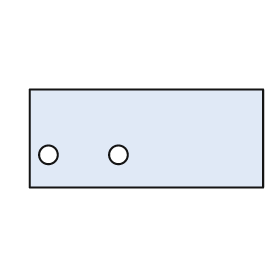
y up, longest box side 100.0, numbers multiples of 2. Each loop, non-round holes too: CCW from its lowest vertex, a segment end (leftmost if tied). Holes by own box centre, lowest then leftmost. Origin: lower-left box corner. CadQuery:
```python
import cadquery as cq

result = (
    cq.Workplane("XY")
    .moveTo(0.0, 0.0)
    .lineTo(100.0, 0.0)
    .lineTo(100.0, 42.0)
    .lineTo(0.0, 42.0)
    .close()
    .moveTo(8.0, 14.0)
    .circle(4.0)
    .moveTo(38.0, 14.0)
    .circle(4.0)
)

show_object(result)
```